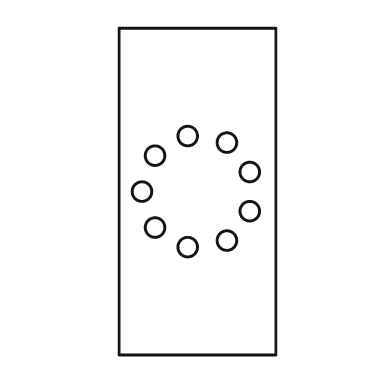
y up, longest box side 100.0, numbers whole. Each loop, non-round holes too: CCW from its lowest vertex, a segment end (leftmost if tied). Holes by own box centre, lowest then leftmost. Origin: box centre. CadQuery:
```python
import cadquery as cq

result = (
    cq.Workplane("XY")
    .moveTo(-24.0, -50.0)
    .lineTo(24.0, -50.0)
    .lineTo(24.0, 50.0)
    .lineTo(-24.0, 50.0)
    .close()
    .moveTo(-3.0, -17.0)
    .circle(3.0)
    .moveTo(9.0, -15.0)
    .circle(3.0)
    .moveTo(-13.0, -11.0)
    .circle(3.0)
    .moveTo(16.0, -6.0)
    .circle(3.0)
    .moveTo(-17.0, 0.0)
    .circle(3.0)
    .moveTo(16.0, 6.0)
    .circle(3.0)
    .moveTo(-13.0, 11.0)
    .circle(3.0)
    .moveTo(9.0, 15.0)
    .circle(3.0)
    .moveTo(-3.0, 17.0)
    .circle(3.0)
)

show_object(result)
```